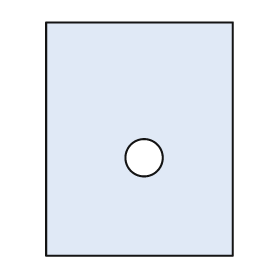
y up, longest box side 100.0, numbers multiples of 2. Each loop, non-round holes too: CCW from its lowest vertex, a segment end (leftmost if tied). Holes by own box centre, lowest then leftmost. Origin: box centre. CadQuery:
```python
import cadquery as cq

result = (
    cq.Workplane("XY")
    .moveTo(-40.0, -50.0)
    .lineTo(40.0, -50.0)
    .lineTo(40.0, 50.0)
    .lineTo(-40.0, 50.0)
    .close()
    .moveTo(2.0, -8.0)
    .circle(8.0)
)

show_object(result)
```